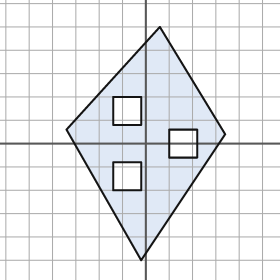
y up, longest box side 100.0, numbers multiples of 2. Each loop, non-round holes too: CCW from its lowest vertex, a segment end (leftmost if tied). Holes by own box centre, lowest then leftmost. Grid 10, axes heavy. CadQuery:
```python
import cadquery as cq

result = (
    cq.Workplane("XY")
    .moveTo(-2.0, -50.0)
    .lineTo(34.0, 4.0)
    .lineTo(6.0, 50.0)
    .lineTo(-34.0, 6.0)
    .close()
    .moveTo(-14.0, -20.0)
    .lineTo(-2.0, -20.0)
    .lineTo(-2.0, -8.0)
    .lineTo(-14.0, -8.0)
    .close()
    .moveTo(10.0, -6.0)
    .lineTo(22.0, -6.0)
    .lineTo(22.0, 6.0)
    .lineTo(10.0, 6.0)
    .close()
    .moveTo(-14.0, 8.0)
    .lineTo(-2.0, 8.0)
    .lineTo(-2.0, 20.0)
    .lineTo(-14.0, 20.0)
    .close()
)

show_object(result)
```